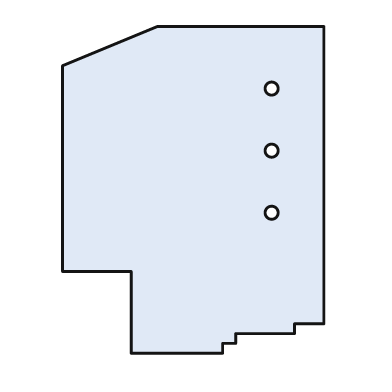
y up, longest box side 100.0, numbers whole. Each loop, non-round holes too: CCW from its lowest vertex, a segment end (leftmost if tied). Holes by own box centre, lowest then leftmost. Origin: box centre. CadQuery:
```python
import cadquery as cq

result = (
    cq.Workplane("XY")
    .moveTo(-19.0, -50.0)
    .lineTo(9.0, -50.0)
    .lineTo(9.0, -47.0)
    .lineTo(13.0, -47.0)
    .lineTo(13.0, -44.0)
    .lineTo(31.0, -44.0)
    .lineTo(31.0, -41.0)
    .lineTo(40.0, -41.0)
    .lineTo(40.0, 50.0)
    .lineTo(-11.0, 50.0)
    .lineTo(-40.0, 38.0)
    .lineTo(-40.0, -25.0)
    .lineTo(-19.0, -25.0)
    .close()
    .moveTo(24.0, -7.0)
    .circle(2.0)
    .moveTo(24.0, 12.0)
    .circle(2.0)
    .moveTo(24.0, 31.0)
    .circle(2.0)
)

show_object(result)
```